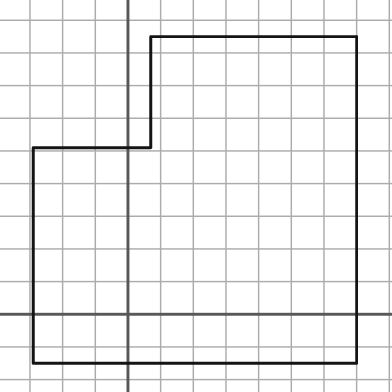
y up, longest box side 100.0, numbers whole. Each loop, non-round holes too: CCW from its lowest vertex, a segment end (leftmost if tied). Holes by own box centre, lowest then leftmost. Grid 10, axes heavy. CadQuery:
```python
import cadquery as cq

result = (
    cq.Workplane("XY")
    .moveTo(-29.0, -15.0)
    .lineTo(70.0, -15.0)
    .lineTo(70.0, 85.0)
    .lineTo(7.0, 85.0)
    .lineTo(7.0, 51.0)
    .lineTo(-29.0, 51.0)
    .close()
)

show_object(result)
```